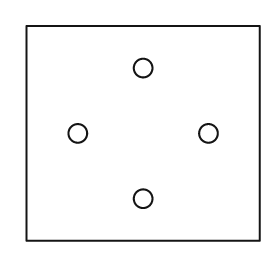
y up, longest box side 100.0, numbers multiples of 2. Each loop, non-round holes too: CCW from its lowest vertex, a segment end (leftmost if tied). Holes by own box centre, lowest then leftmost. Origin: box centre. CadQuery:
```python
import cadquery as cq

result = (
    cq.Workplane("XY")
    .moveTo(-50.0, -46.0)
    .lineTo(50.0, -46.0)
    .lineTo(50.0, 46.0)
    .lineTo(-50.0, 46.0)
    .close()
    .moveTo(0.0, -28.0)
    .circle(4.0)
    .moveTo(-28.0, 0.0)
    .circle(4.0)
    .moveTo(28.0, 0.0)
    .circle(4.0)
    .moveTo(0.0, 28.0)
    .circle(4.0)
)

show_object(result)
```